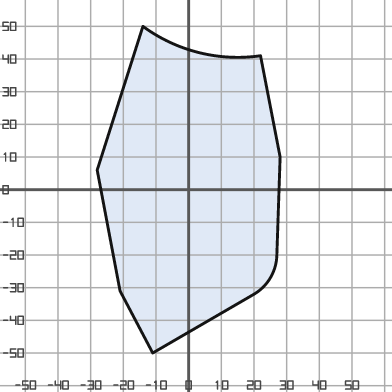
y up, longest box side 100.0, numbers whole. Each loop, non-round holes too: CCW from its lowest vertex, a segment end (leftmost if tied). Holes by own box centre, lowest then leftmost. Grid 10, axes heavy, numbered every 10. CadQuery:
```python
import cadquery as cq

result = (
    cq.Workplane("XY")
    .moveTo(-11.0, -50.0)
    .lineTo(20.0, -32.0)
    .threePointArc((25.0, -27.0), (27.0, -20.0))
    .lineTo(28.0, 10.0)
    .lineTo(22.0, 41.0)
    .threePointArc((3.0, 42.0), (-14.0, 50.0))
    .lineTo(-28.0, 6.0)
    .lineTo(-21.0, -31.0)
    .close()
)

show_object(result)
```